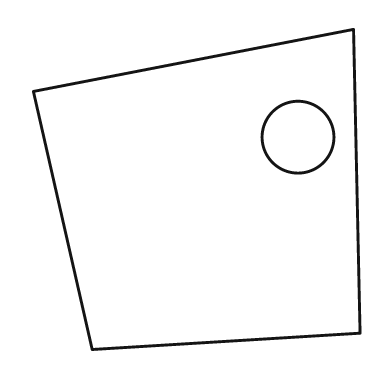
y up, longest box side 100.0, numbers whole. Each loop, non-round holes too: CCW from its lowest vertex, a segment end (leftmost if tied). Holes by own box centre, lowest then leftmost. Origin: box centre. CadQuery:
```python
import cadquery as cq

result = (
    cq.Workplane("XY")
    .moveTo(-32.0, -49.0)
    .lineTo(50.0, -44.0)
    .lineTo(48.0, 49.0)
    .lineTo(-50.0, 30.0)
    .close()
    .moveTo(31.0, 16.0)
    .circle(11.0)
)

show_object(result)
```